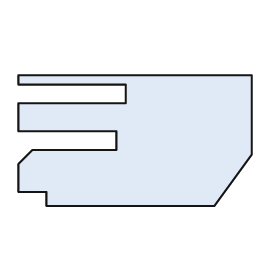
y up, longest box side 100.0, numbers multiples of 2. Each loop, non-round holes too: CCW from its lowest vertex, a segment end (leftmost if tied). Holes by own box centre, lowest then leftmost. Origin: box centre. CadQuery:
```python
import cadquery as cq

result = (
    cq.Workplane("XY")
    .moveTo(-38.0, -28.0)
    .lineTo(34.0, -28.0)
    .lineTo(50.0, -6.0)
    .lineTo(50.0, 28.0)
    .lineTo(-50.0, 28.0)
    .lineTo(-50.0, 24.0)
    .lineTo(-4.0, 24.0)
    .lineTo(-4.0, 16.0)
    .lineTo(-50.0, 16.0)
    .lineTo(-50.0, 4.0)
    .lineTo(-8.0, 4.0)
    .lineTo(-8.0, -4.0)
    .lineTo(-44.0, -4.0)
    .lineTo(-50.0, -10.0)
    .lineTo(-50.0, -22.0)
    .lineTo(-38.0, -22.0)
    .close()
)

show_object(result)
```